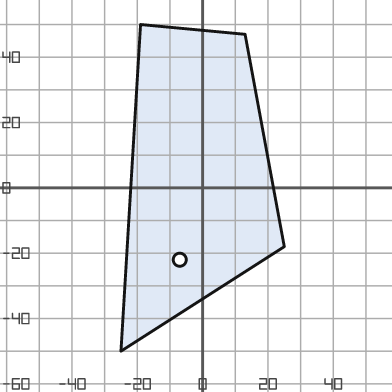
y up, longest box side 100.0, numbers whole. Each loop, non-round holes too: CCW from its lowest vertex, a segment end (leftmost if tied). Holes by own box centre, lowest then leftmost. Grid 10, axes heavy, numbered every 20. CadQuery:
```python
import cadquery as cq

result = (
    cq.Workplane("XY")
    .moveTo(-25.0, -50.0)
    .lineTo(25.0, -18.0)
    .lineTo(13.0, 47.0)
    .lineTo(-19.0, 50.0)
    .close()
    .moveTo(-7.0, -22.0)
    .circle(2.0)
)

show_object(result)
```